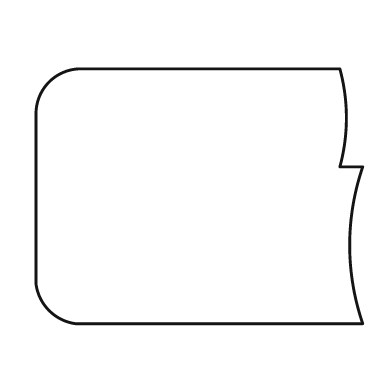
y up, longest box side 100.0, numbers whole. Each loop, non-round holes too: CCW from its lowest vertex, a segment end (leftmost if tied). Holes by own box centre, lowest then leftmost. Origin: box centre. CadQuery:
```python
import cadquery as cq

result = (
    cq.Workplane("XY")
    .moveTo(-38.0, -39.0)
    .lineTo(50.0, -39.0)
    .threePointArc((46.0, -15.0), (50.0, 9.0))
    .lineTo(43.0, 9.0)
    .threePointArc((45.0, 24.0), (43.0, 39.0))
    .lineTo(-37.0, 39.0)
    .threePointArc((-46.0, 35.0), (-50.0, 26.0))
    .lineTo(-50.0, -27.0)
    .threePointArc((-46.0, -35.0), (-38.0, -39.0))
    .close()
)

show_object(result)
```